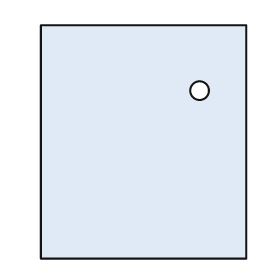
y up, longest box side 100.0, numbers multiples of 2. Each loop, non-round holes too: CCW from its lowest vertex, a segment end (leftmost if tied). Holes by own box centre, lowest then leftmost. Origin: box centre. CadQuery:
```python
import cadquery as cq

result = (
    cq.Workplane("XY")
    .moveTo(-44.0, -50.0)
    .lineTo(44.0, -50.0)
    .lineTo(44.0, 50.0)
    .lineTo(-44.0, 50.0)
    .close()
    .moveTo(24.0, 22.0)
    .circle(4.0)
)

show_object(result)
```